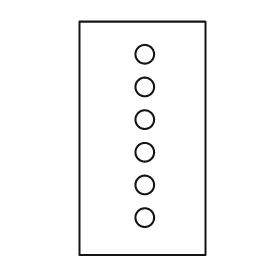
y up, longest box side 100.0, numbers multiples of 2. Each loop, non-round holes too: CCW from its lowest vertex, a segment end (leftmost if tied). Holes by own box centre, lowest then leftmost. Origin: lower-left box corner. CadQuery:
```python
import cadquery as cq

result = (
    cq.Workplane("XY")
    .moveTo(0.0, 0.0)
    .lineTo(54.0, 0.0)
    .lineTo(54.0, 100.0)
    .lineTo(0.0, 100.0)
    .close()
    .moveTo(28.0, 16.0)
    .circle(4.0)
    .moveTo(28.0, 30.0)
    .circle(4.0)
    .moveTo(28.0, 44.0)
    .circle(4.0)
    .moveTo(28.0, 58.0)
    .circle(4.0)
    .moveTo(28.0, 72.0)
    .circle(4.0)
    .moveTo(28.0, 86.0)
    .circle(4.0)
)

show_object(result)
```